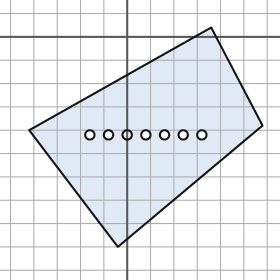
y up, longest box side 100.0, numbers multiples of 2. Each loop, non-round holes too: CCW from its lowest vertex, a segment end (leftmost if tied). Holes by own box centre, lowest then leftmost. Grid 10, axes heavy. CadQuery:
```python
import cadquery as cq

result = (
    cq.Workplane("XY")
    .moveTo(-4.0, -90.0)
    .lineTo(58.0, -38.0)
    .lineTo(36.0, 4.0)
    .lineTo(-42.0, -40.0)
    .close()
    .moveTo(-16.0, -42.0)
    .circle(2.0)
    .moveTo(-8.0, -42.0)
    .circle(2.0)
    .moveTo(0.0, -42.0)
    .circle(2.0)
    .moveTo(8.0, -42.0)
    .circle(2.0)
    .moveTo(16.0, -42.0)
    .circle(2.0)
    .moveTo(24.0, -42.0)
    .circle(2.0)
    .moveTo(32.0, -42.0)
    .circle(2.0)
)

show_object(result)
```